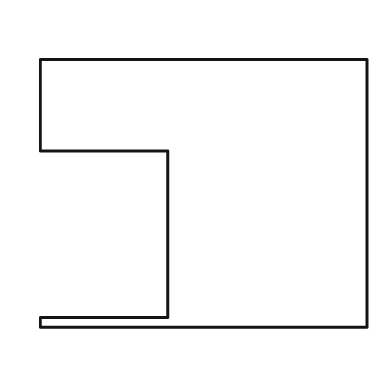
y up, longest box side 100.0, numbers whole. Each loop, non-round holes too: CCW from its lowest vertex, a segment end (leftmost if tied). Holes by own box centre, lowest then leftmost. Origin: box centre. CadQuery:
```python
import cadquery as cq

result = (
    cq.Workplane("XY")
    .moveTo(-50.0, -41.0)
    .lineTo(50.0, -41.0)
    .lineTo(50.0, 41.0)
    .lineTo(-50.0, 41.0)
    .lineTo(-50.0, 13.0)
    .lineTo(-11.0, 13.0)
    .lineTo(-11.0, -38.0)
    .lineTo(-50.0, -38.0)
    .close()
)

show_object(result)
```